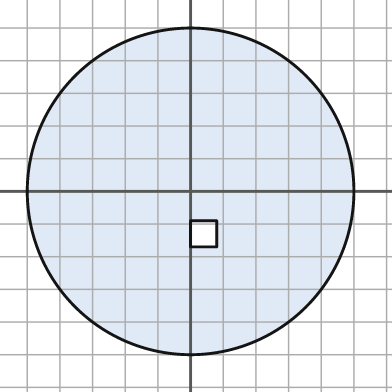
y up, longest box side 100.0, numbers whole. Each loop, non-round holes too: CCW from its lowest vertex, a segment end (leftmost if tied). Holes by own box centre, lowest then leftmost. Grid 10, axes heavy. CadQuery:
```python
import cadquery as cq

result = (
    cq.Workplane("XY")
    .moveTo(0.0, 0.0)
    .circle(50.0)
    .moveTo(0.0, -17.0)
    .lineTo(8.0, -17.0)
    .lineTo(8.0, -9.0)
    .lineTo(0.0, -9.0)
    .close()
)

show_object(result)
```